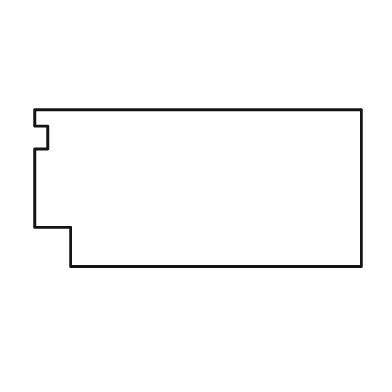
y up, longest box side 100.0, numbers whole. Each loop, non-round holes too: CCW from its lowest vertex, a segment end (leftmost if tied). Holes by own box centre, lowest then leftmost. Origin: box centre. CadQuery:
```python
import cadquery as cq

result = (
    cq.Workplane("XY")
    .moveTo(-39.0, -24.0)
    .lineTo(50.0, -24.0)
    .lineTo(50.0, 24.0)
    .lineTo(-50.0, 24.0)
    .lineTo(-50.0, 19.0)
    .lineTo(-46.0, 19.0)
    .lineTo(-46.0, 12.0)
    .lineTo(-50.0, 12.0)
    .lineTo(-50.0, -12.0)
    .lineTo(-39.0, -12.0)
    .close()
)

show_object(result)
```